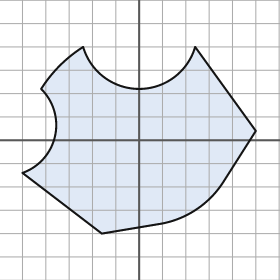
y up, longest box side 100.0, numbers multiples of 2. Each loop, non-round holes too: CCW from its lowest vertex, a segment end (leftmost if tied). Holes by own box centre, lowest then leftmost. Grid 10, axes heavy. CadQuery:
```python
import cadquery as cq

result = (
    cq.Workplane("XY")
    .moveTo(-16.0, -40.0)
    .lineTo(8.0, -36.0)
    .threePointArc((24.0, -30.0), (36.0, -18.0))
    .lineTo(50.0, 4.0)
    .lineTo(24.0, 40.0)
    .threePointArc((0.0, 22.0), (-24.0, 40.0))
    .threePointArc((-34.0, 32.0), (-42.0, 22.0))
    .threePointArc((-36.0, 2.0), (-50.0, -14.0))
    .close()
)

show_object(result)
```